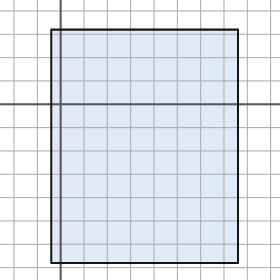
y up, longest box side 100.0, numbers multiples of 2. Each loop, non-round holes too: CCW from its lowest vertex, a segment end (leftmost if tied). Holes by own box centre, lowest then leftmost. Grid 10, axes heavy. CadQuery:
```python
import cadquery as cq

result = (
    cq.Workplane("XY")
    .moveTo(-4.0, -68.0)
    .lineTo(76.0, -68.0)
    .lineTo(76.0, 32.0)
    .lineTo(-4.0, 32.0)
    .close()
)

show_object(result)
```